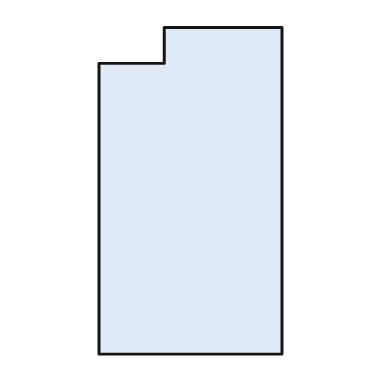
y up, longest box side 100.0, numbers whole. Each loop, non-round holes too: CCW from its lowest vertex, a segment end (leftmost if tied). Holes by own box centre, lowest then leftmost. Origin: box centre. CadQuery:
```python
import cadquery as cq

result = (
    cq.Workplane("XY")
    .moveTo(-28.0, -50.0)
    .lineTo(28.0, -50.0)
    .lineTo(28.0, 50.0)
    .lineTo(-8.0, 50.0)
    .lineTo(-8.0, 39.0)
    .lineTo(-28.0, 39.0)
    .close()
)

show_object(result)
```